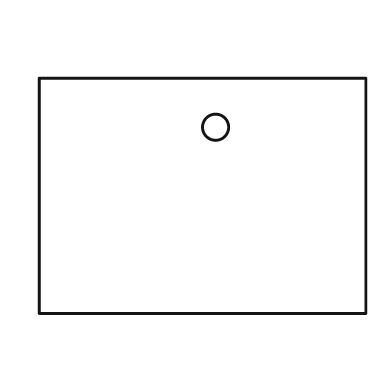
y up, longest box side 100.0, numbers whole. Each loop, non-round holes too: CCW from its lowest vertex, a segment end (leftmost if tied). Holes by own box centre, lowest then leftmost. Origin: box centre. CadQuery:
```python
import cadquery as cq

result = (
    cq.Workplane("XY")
    .moveTo(-50.0, -36.0)
    .lineTo(50.0, -36.0)
    .lineTo(50.0, 36.0)
    .lineTo(-50.0, 36.0)
    .close()
    .moveTo(4.0, 21.0)
    .circle(4.0)
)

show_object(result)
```